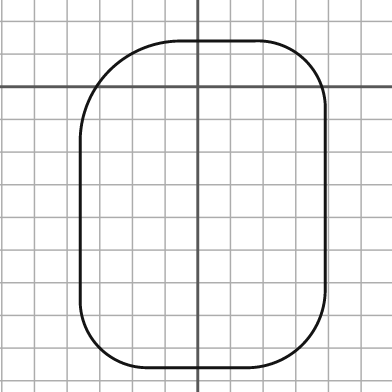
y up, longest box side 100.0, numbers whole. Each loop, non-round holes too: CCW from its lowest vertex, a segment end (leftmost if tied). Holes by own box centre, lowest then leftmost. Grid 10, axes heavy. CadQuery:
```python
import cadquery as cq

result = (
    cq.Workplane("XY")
    .moveTo(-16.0, -86.0)
    .lineTo(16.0, -86.0)
    .threePointArc((32.0, -79.0), (39.0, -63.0))
    .lineTo(39.0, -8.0)
    .threePointArc((33.0, 8.0), (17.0, 14.0))
    .lineTo(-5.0, 14.0)
    .threePointArc((-27.0, 5.0), (-36.0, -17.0))
    .lineTo(-36.0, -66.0)
    .threePointArc((-30.0, -80.0), (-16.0, -86.0))
    .close()
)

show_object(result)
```